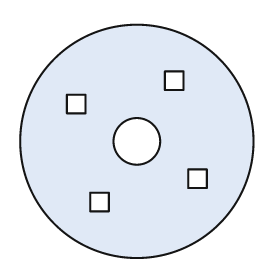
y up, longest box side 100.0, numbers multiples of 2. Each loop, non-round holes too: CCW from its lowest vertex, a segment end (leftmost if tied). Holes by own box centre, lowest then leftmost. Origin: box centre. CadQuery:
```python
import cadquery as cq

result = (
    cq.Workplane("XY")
    .moveTo(0.0, 0.0)
    .circle(50.0)
    .moveTo(-20.0, -30.0)
    .lineTo(-12.0, -30.0)
    .lineTo(-12.0, -22.0)
    .lineTo(-20.0, -22.0)
    .close()
    .moveTo(22.0, -20.0)
    .lineTo(30.0, -20.0)
    .lineTo(30.0, -12.0)
    .lineTo(22.0, -12.0)
    .close()
    .moveTo(0.0, 0.0)
    .circle(10.0)
    .moveTo(-30.0, 12.0)
    .lineTo(-22.0, 12.0)
    .lineTo(-22.0, 20.0)
    .lineTo(-30.0, 20.0)
    .close()
    .moveTo(12.0, 22.0)
    .lineTo(20.0, 22.0)
    .lineTo(20.0, 30.0)
    .lineTo(12.0, 30.0)
    .close()
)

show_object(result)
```